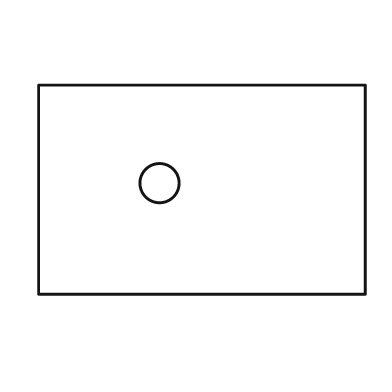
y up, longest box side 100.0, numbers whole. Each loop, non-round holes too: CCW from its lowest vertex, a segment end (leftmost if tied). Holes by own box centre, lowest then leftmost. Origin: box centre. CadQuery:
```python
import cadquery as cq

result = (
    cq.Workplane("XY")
    .moveTo(-50.0, -32.0)
    .lineTo(50.0, -32.0)
    .lineTo(50.0, 32.0)
    .lineTo(-50.0, 32.0)
    .close()
    .moveTo(-13.0, 2.0)
    .circle(6.0)
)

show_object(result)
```